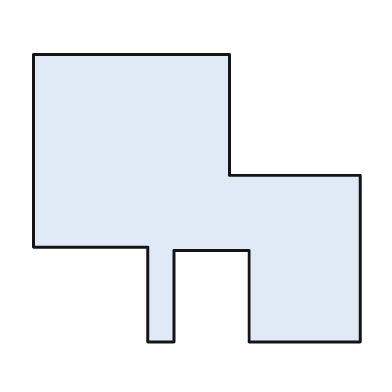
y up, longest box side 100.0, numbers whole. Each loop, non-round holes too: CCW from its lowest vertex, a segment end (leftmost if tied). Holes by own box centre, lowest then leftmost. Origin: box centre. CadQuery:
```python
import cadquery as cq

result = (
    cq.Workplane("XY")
    .moveTo(-15.0, -44.0)
    .lineTo(-7.0, -44.0)
    .lineTo(-7.0, -16.0)
    .lineTo(16.0, -16.0)
    .lineTo(16.0, -44.0)
    .lineTo(50.0, -44.0)
    .lineTo(50.0, 7.0)
    .lineTo(10.0, 7.0)
    .lineTo(10.0, 44.0)
    .lineTo(-50.0, 44.0)
    .lineTo(-50.0, -15.0)
    .lineTo(-15.0, -15.0)
    .close()
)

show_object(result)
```